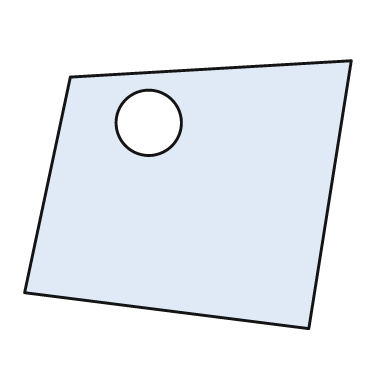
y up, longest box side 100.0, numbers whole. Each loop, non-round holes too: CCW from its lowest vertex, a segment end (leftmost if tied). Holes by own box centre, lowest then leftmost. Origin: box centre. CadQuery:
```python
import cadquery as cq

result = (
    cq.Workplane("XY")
    .moveTo(37.0, -41.0)
    .lineTo(50.0, 41.0)
    .lineTo(-36.0, 36.0)
    .lineTo(-50.0, -30.0)
    .close()
    .moveTo(-12.0, 22.0)
    .circle(10.0)
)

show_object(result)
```